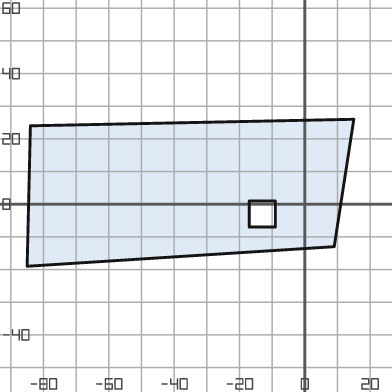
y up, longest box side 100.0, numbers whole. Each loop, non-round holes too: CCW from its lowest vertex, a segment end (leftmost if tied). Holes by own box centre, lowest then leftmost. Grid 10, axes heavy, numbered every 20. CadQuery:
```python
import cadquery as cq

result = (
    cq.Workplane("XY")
    .moveTo(-85.0, -19.0)
    .lineTo(9.0, -13.0)
    .lineTo(15.0, 26.0)
    .lineTo(-84.0, 24.0)
    .close()
    .moveTo(-17.0, -7.0)
    .lineTo(-9.0, -7.0)
    .lineTo(-9.0, 1.0)
    .lineTo(-17.0, 1.0)
    .close()
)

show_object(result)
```